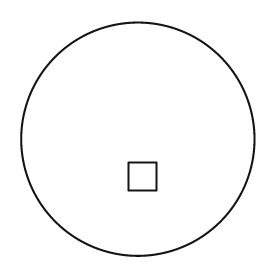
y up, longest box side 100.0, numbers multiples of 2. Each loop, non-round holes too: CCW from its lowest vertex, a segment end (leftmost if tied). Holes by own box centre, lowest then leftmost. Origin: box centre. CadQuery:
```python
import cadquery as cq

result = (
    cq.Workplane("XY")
    .moveTo(0.0, 0.0)
    .circle(50.0)
    .moveTo(-4.0, -22.0)
    .lineTo(8.0, -22.0)
    .lineTo(8.0, -10.0)
    .lineTo(-4.0, -10.0)
    .close()
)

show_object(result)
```